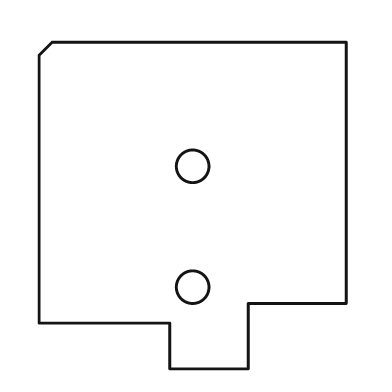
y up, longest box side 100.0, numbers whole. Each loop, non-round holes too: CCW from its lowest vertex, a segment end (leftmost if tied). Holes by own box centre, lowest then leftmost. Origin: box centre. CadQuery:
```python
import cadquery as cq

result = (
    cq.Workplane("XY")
    .moveTo(-7.0, -50.0)
    .lineTo(17.0, -50.0)
    .lineTo(17.0, -30.0)
    .lineTo(47.0, -30.0)
    .lineTo(47.0, 50.0)
    .lineTo(-43.0, 50.0)
    .lineTo(-47.0, 46.0)
    .lineTo(-47.0, -36.0)
    .lineTo(-7.0, -36.0)
    .close()
    .moveTo(0.0, -25.0)
    .circle(5.0)
    .moveTo(0.0, 12.0)
    .circle(5.0)
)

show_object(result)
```